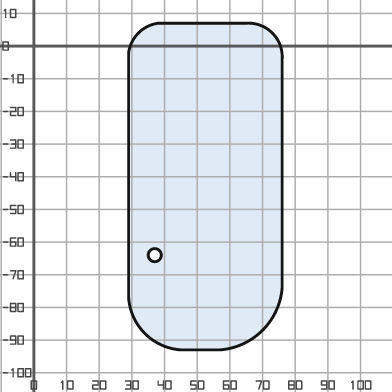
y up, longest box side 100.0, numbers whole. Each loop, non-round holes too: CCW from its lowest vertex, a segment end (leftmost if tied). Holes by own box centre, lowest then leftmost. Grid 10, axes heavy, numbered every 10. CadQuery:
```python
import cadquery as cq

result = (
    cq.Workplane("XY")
    .moveTo(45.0, -93.0)
    .lineTo(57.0, -93.0)
    .threePointArc((70.0, -87.0), (76.0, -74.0))
    .lineTo(76.0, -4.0)
    .threePointArc((73.0, 4.0), (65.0, 7.0))
    .lineTo(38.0, 7.0)
    .threePointArc((32.0, 4.0), (29.0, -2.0))
    .lineTo(29.0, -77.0)
    .threePointArc((34.0, -88.0), (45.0, -93.0))
    .close()
    .moveTo(37.0, -64.0)
    .circle(2.0)
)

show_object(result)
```